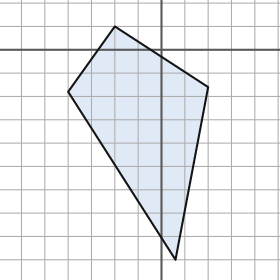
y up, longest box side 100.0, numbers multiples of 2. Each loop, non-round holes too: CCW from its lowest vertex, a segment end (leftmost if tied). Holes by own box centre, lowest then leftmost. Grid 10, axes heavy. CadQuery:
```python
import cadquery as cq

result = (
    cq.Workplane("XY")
    .moveTo(6.0, -90.0)
    .lineTo(20.0, -16.0)
    .lineTo(-20.0, 10.0)
    .lineTo(-40.0, -18.0)
    .close()
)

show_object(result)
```